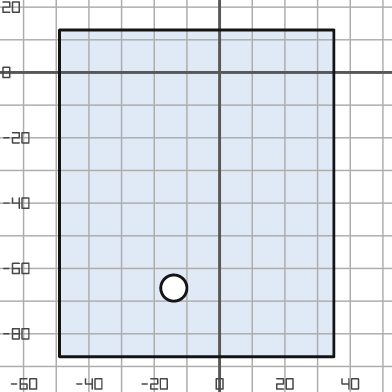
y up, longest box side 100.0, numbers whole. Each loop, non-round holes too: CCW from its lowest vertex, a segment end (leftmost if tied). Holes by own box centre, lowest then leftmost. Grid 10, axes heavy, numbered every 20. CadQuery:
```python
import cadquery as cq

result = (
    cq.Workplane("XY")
    .moveTo(-49.0, -87.0)
    .lineTo(35.0, -87.0)
    .lineTo(35.0, 13.0)
    .lineTo(-49.0, 13.0)
    .close()
    .moveTo(-14.0, -66.0)
    .circle(4.0)
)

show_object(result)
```